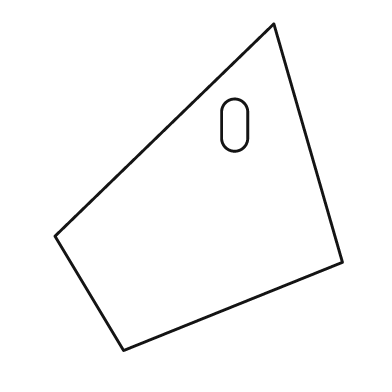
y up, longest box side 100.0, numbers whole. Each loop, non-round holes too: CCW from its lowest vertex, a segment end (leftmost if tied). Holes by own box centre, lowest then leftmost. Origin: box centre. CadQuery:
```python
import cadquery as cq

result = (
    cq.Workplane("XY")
    .moveTo(-23.0, -50.0)
    .lineTo(44.0, -23.0)
    .lineTo(23.0, 50.0)
    .lineTo(-44.0, -15.0)
    .close()
    .moveTo(7.0, 15.0)
    .threePointArc((11.0, 11.0), (15.0, 15.0))
    .lineTo(15.0, 23.0)
    .threePointArc((11.0, 27.0), (7.0, 23.0))
    .close()
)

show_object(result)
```